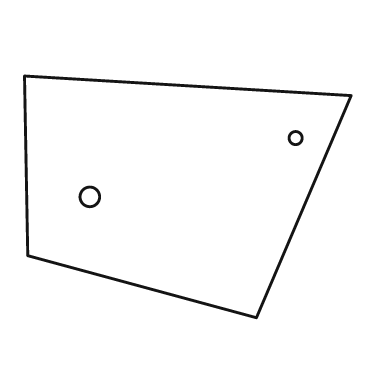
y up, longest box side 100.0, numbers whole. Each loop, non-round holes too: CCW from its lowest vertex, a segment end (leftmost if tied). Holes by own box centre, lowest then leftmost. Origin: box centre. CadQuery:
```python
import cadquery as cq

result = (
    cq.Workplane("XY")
    .moveTo(21.0, -37.0)
    .lineTo(50.0, 31.0)
    .lineTo(-50.0, 37.0)
    .lineTo(-49.0, -18.0)
    .close()
    .moveTo(-30.0, 0.0)
    .circle(3.0)
    .moveTo(33.0, 18.0)
    .circle(2.0)
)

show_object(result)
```